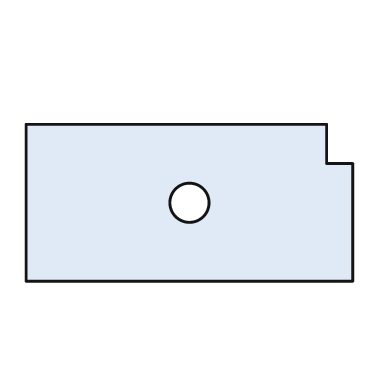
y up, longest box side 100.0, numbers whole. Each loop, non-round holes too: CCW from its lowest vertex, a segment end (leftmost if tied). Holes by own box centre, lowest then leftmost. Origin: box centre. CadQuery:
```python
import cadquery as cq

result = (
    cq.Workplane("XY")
    .moveTo(-50.0, -24.0)
    .lineTo(50.0, -24.0)
    .lineTo(50.0, 12.0)
    .lineTo(42.0, 12.0)
    .lineTo(42.0, 24.0)
    .lineTo(-50.0, 24.0)
    .close()
    .moveTo(0.0, 0.0)
    .circle(6.0)
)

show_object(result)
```